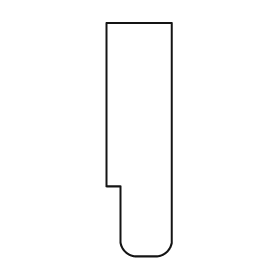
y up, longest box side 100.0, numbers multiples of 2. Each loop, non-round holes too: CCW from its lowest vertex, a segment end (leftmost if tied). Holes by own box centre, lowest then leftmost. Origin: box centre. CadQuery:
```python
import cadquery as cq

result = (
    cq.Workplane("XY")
    .moveTo(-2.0, -50.0)
    .lineTo(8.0, -50.0)
    .threePointArc((12.0, -48.0), (14.0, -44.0))
    .lineTo(14.0, 50.0)
    .lineTo(-14.0, 50.0)
    .lineTo(-14.0, -20.0)
    .lineTo(-8.0, -20.0)
    .lineTo(-8.0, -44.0)
    .threePointArc((-6.0, -48.0), (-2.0, -50.0))
    .close()
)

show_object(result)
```